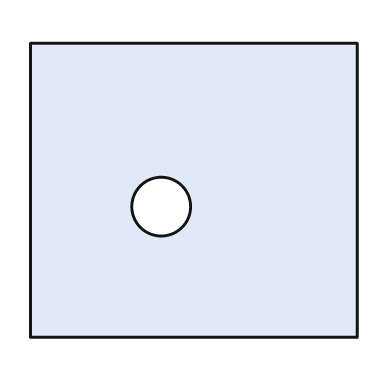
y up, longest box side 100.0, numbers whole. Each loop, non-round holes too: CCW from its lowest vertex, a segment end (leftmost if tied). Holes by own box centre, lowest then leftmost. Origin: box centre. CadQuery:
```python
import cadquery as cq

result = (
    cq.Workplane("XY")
    .moveTo(-50.0, -45.0)
    .lineTo(50.0, -45.0)
    .lineTo(50.0, 45.0)
    .lineTo(-50.0, 45.0)
    .close()
    .moveTo(-10.0, -5.0)
    .circle(9.0)
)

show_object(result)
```